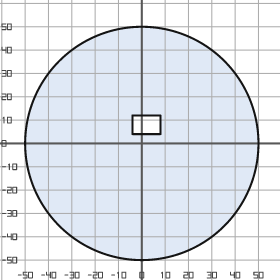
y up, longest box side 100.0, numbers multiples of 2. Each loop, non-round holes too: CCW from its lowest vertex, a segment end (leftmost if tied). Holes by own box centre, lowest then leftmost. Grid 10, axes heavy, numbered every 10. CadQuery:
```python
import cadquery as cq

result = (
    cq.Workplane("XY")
    .moveTo(0.0, 0.0)
    .circle(50.0)
    .moveTo(-4.0, 4.0)
    .lineTo(8.0, 4.0)
    .lineTo(8.0, 12.0)
    .lineTo(-4.0, 12.0)
    .close()
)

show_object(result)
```